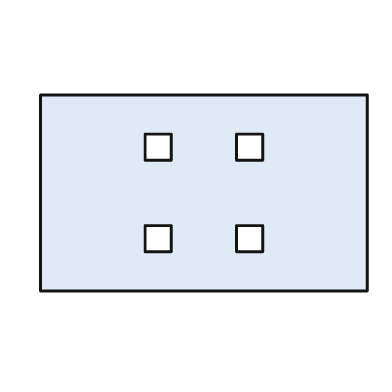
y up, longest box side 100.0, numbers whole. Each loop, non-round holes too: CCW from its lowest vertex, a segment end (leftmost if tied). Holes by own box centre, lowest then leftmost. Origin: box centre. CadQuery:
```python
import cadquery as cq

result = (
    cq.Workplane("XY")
    .moveTo(-50.0, -30.0)
    .lineTo(50.0, -30.0)
    .lineTo(50.0, 30.0)
    .lineTo(-50.0, 30.0)
    .close()
    .moveTo(-18.0, -18.0)
    .lineTo(-10.0, -18.0)
    .lineTo(-10.0, -10.0)
    .lineTo(-18.0, -10.0)
    .close()
    .moveTo(10.0, -18.0)
    .lineTo(18.0, -18.0)
    .lineTo(18.0, -10.0)
    .lineTo(10.0, -10.0)
    .close()
    .moveTo(-18.0, 10.0)
    .lineTo(-10.0, 10.0)
    .lineTo(-10.0, 18.0)
    .lineTo(-18.0, 18.0)
    .close()
    .moveTo(10.0, 10.0)
    .lineTo(18.0, 10.0)
    .lineTo(18.0, 18.0)
    .lineTo(10.0, 18.0)
    .close()
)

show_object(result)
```